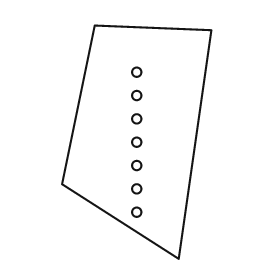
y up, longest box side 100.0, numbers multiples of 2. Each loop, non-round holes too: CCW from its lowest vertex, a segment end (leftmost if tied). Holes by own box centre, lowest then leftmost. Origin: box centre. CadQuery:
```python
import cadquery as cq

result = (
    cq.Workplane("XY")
    .moveTo(18.0, -50.0)
    .lineTo(32.0, 48.0)
    .lineTo(-18.0, 50.0)
    .lineTo(-32.0, -18.0)
    .close()
    .moveTo(0.0, -30.0)
    .circle(2.0)
    .moveTo(0.0, -20.0)
    .circle(2.0)
    .moveTo(0.0, -10.0)
    .circle(2.0)
    .moveTo(0.0, 0.0)
    .circle(2.0)
    .moveTo(0.0, 10.0)
    .circle(2.0)
    .moveTo(0.0, 20.0)
    .circle(2.0)
    .moveTo(0.0, 30.0)
    .circle(2.0)
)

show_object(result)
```